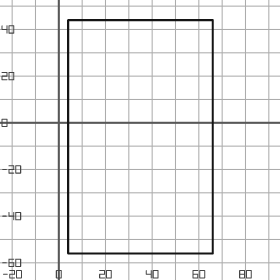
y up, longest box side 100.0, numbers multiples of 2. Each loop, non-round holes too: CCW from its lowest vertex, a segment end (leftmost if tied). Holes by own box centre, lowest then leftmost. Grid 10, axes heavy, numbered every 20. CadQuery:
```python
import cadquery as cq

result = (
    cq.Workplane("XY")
    .moveTo(4.0, -56.0)
    .lineTo(66.0, -56.0)
    .lineTo(66.0, 44.0)
    .lineTo(4.0, 44.0)
    .close()
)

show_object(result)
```